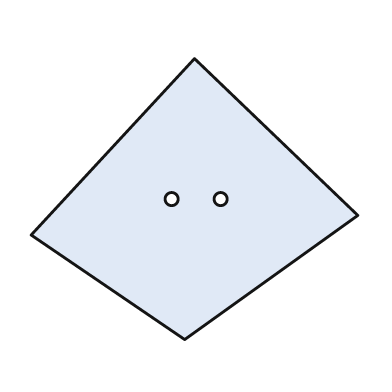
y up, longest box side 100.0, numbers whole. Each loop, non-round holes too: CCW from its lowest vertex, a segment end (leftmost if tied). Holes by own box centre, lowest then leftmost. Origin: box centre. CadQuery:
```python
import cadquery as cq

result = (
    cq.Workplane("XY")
    .moveTo(-3.0, -43.0)
    .lineTo(50.0, -5.0)
    .lineTo(0.0, 43.0)
    .lineTo(-50.0, -11.0)
    .close()
    .moveTo(-7.0, 0.0)
    .circle(2.0)
    .moveTo(8.0, 0.0)
    .circle(2.0)
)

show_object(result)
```